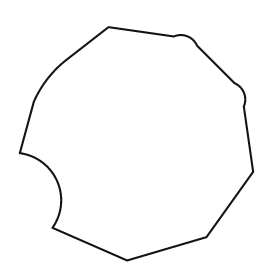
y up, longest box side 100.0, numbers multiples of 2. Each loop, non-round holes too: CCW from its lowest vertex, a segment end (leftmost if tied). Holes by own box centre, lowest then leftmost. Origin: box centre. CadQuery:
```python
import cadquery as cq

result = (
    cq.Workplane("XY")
    .moveTo(-4.0, -50.0)
    .lineTo(30.0, -40.0)
    .lineTo(50.0, -12.0)
    .lineTo(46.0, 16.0)
    .threePointArc((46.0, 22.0), (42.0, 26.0))
    .lineTo(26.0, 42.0)
    .threePointArc((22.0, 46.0), (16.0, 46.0))
    .lineTo(-12.0, 50.0)
    .lineTo(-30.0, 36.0)
    .threePointArc((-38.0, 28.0), (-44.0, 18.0))
    .lineTo(-50.0, -4.0)
    .threePointArc((-34.0, -16.0), (-36.0, -36.0))
    .close()
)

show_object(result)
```